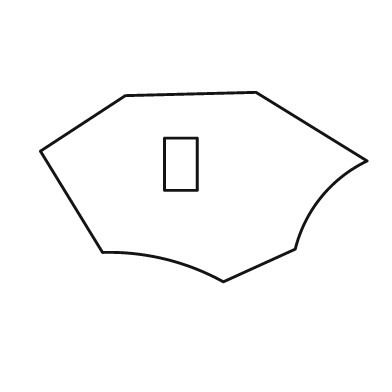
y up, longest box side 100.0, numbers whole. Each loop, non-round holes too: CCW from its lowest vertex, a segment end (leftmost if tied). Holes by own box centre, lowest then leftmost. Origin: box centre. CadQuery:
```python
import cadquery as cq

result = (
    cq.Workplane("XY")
    .moveTo(6.0, -29.0)
    .lineTo(28.0, -19.0)
    .threePointArc((36.0, -3.0), (50.0, 8.0))
    .lineTo(16.0, 29.0)
    .lineTo(-24.0, 28.0)
    .lineTo(-50.0, 11.0)
    .lineTo(-31.0, -20.0)
    .threePointArc((-12.0, -22.0), (6.0, -29.0))
    .close()
    .moveTo(-12.0, -1.0)
    .lineTo(-2.0, -1.0)
    .lineTo(-2.0, 15.0)
    .lineTo(-12.0, 15.0)
    .close()
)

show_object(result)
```